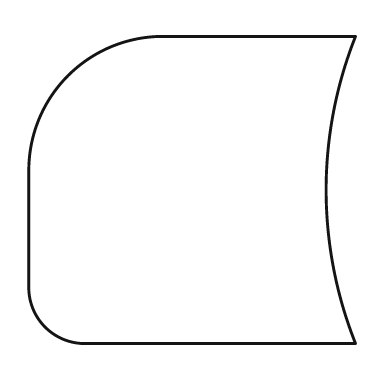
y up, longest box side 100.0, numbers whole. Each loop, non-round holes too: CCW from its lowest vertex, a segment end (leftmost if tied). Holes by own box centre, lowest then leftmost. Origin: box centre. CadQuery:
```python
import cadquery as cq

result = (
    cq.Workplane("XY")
    .moveTo(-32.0, -47.0)
    .lineTo(50.0, -47.0)
    .threePointArc((41.0, 0.0), (50.0, 47.0))
    .lineTo(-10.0, 47.0)
    .threePointArc((-38.0, 35.0), (-50.0, 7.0))
    .lineTo(-50.0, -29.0)
    .threePointArc((-45.0, -42.0), (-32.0, -47.0))
    .close()
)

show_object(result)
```